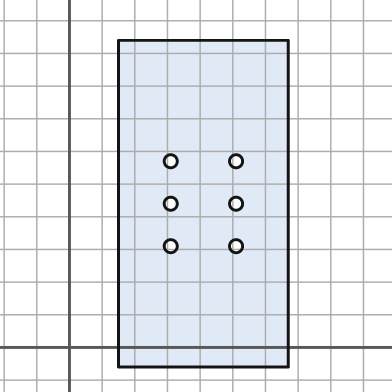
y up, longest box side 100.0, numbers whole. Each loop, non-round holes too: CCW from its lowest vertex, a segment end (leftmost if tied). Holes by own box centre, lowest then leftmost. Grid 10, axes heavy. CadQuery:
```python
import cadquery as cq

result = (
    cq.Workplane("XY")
    .moveTo(15.0, -6.0)
    .lineTo(67.0, -6.0)
    .lineTo(67.0, 94.0)
    .lineTo(15.0, 94.0)
    .close()
    .moveTo(31.0, 31.0)
    .circle(2.0)
    .moveTo(51.0, 31.0)
    .circle(2.0)
    .moveTo(31.0, 44.0)
    .circle(2.0)
    .moveTo(51.0, 44.0)
    .circle(2.0)
    .moveTo(31.0, 57.0)
    .circle(2.0)
    .moveTo(51.0, 57.0)
    .circle(2.0)
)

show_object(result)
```